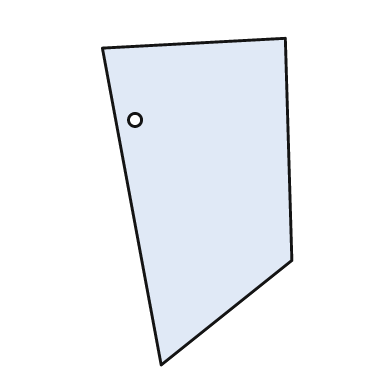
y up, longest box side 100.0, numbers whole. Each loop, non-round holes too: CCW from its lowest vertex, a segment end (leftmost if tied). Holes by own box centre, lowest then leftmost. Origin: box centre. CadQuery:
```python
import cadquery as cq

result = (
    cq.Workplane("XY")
    .moveTo(-11.0, -50.0)
    .lineTo(29.0, -18.0)
    .lineTo(27.0, 50.0)
    .lineTo(-29.0, 47.0)
    .close()
    .moveTo(-19.0, 25.0)
    .circle(2.0)
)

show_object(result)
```